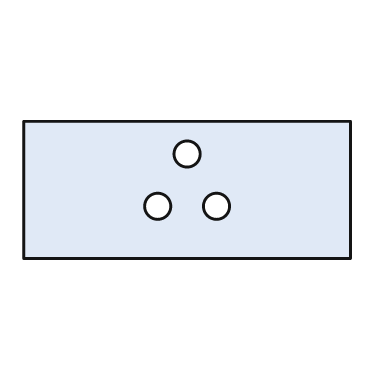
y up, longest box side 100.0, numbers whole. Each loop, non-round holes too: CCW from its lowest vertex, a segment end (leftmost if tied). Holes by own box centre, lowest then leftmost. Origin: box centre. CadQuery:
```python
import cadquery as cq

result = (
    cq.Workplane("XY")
    .moveTo(-50.0, -21.0)
    .lineTo(50.0, -21.0)
    .lineTo(50.0, 21.0)
    .lineTo(-50.0, 21.0)
    .close()
    .moveTo(-9.0, -5.0)
    .circle(4.0)
    .moveTo(9.0, -5.0)
    .circle(4.0)
    .moveTo(0.0, 11.0)
    .circle(4.0)
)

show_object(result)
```